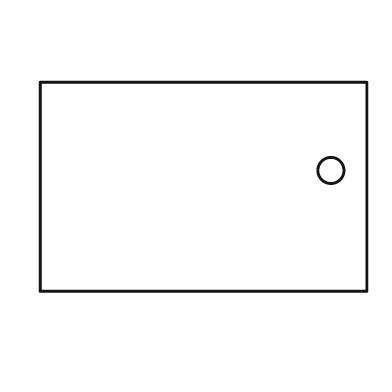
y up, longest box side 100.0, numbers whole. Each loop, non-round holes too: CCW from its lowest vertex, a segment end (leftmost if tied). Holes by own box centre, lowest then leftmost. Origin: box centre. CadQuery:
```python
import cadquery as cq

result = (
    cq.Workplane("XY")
    .moveTo(-50.0, -32.0)
    .lineTo(50.0, -32.0)
    .lineTo(50.0, 32.0)
    .lineTo(-50.0, 32.0)
    .close()
    .moveTo(39.0, 5.0)
    .circle(4.0)
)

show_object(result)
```